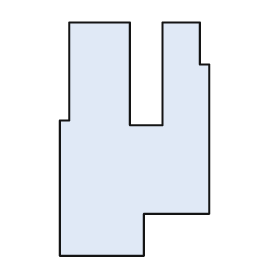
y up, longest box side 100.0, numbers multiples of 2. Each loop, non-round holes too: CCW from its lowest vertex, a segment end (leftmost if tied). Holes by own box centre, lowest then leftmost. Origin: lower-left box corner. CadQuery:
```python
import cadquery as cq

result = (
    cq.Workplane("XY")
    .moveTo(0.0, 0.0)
    .lineTo(36.0, 0.0)
    .lineTo(36.0, 18.0)
    .lineTo(64.0, 18.0)
    .lineTo(64.0, 82.0)
    .lineTo(60.0, 82.0)
    .lineTo(60.0, 100.0)
    .lineTo(44.0, 100.0)
    .lineTo(44.0, 56.0)
    .lineTo(30.0, 56.0)
    .lineTo(30.0, 100.0)
    .lineTo(4.0, 100.0)
    .lineTo(4.0, 58.0)
    .lineTo(0.0, 58.0)
    .close()
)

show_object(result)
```